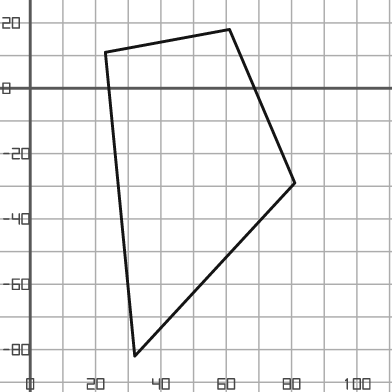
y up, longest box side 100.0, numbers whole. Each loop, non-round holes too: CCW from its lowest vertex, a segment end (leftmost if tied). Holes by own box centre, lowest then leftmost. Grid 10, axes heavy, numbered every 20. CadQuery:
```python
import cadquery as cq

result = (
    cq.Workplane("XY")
    .moveTo(32.0, -82.0)
    .lineTo(81.0, -29.0)
    .lineTo(61.0, 18.0)
    .lineTo(23.0, 11.0)
    .close()
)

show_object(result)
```